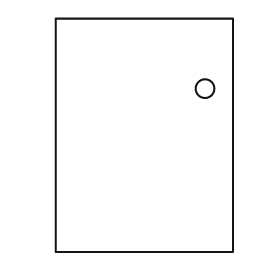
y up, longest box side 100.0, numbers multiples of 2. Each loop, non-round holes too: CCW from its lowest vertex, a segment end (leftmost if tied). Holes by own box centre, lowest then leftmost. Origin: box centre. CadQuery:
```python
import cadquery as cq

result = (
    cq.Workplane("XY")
    .moveTo(-38.0, -50.0)
    .lineTo(38.0, -50.0)
    .lineTo(38.0, 50.0)
    .lineTo(-38.0, 50.0)
    .close()
    .moveTo(26.0, 20.0)
    .circle(4.0)
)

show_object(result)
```